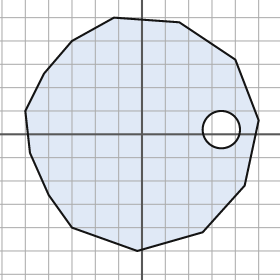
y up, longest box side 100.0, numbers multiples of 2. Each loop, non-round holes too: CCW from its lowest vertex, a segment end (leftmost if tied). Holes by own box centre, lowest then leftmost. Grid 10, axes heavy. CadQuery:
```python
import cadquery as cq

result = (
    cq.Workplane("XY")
    .moveTo(-2.0, -50.0)
    .lineTo(26.0, -42.0)
    .lineTo(44.0, -22.0)
    .lineTo(50.0, 6.0)
    .lineTo(40.0, 32.0)
    .lineTo(16.0, 48.0)
    .lineTo(-12.0, 50.0)
    .lineTo(-30.0, 40.0)
    .lineTo(-42.0, 26.0)
    .lineTo(-50.0, 10.0)
    .lineTo(-48.0, -8.0)
    .lineTo(-40.0, -26.0)
    .lineTo(-30.0, -40.0)
    .close()
    .moveTo(34.0, 2.0)
    .circle(8.0)
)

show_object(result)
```